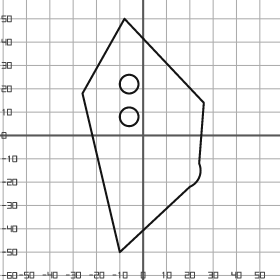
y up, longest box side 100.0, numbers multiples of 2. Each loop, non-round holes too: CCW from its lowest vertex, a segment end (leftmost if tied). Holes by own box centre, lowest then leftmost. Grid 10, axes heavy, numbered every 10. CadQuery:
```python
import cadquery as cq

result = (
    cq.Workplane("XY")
    .moveTo(-10.0, -50.0)
    .lineTo(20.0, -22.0)
    .threePointArc((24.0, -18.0), (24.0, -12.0))
    .lineTo(26.0, 14.0)
    .lineTo(-8.0, 50.0)
    .lineTo(-26.0, 18.0)
    .close()
    .moveTo(-6.0, 8.0)
    .circle(4.0)
    .moveTo(-6.0, 22.0)
    .circle(4.0)
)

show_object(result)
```